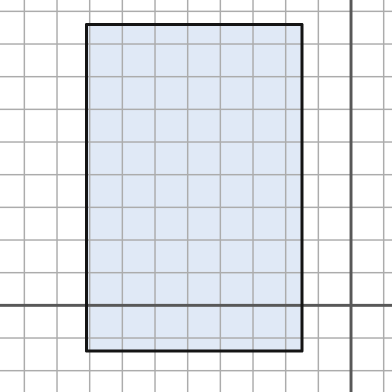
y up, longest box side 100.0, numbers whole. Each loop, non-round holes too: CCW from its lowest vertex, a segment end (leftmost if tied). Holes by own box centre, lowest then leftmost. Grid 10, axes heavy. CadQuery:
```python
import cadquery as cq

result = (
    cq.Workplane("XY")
    .moveTo(-81.0, -14.0)
    .lineTo(-15.0, -14.0)
    .lineTo(-15.0, 86.0)
    .lineTo(-81.0, 86.0)
    .close()
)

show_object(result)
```